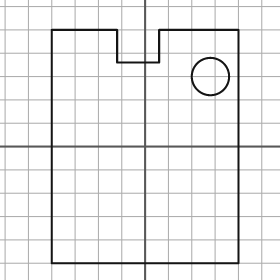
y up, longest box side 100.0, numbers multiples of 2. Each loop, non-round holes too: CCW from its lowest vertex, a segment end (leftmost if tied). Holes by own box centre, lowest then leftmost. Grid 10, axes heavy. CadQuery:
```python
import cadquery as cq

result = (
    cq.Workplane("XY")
    .moveTo(-40.0, -50.0)
    .lineTo(40.0, -50.0)
    .lineTo(40.0, 50.0)
    .lineTo(6.0, 50.0)
    .lineTo(6.0, 36.0)
    .lineTo(-12.0, 36.0)
    .lineTo(-12.0, 50.0)
    .lineTo(-40.0, 50.0)
    .close()
    .moveTo(28.0, 30.0)
    .circle(8.0)
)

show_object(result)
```